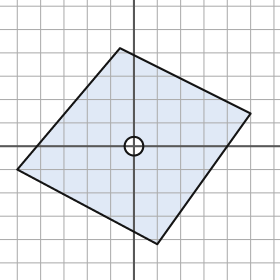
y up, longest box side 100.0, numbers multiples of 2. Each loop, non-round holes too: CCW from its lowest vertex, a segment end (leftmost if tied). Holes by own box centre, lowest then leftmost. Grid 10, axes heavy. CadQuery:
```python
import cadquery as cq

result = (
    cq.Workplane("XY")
    .moveTo(10.0, -42.0)
    .lineTo(50.0, 14.0)
    .lineTo(-6.0, 42.0)
    .lineTo(-50.0, -10.0)
    .close()
    .moveTo(0.0, 0.0)
    .circle(4.0)
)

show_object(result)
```